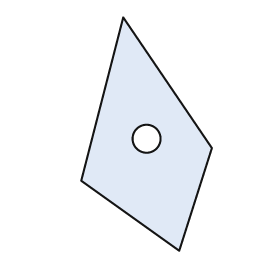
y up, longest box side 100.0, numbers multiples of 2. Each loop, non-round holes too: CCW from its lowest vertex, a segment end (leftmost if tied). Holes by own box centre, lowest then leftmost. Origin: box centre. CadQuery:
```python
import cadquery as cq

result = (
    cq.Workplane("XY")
    .moveTo(14.0, -50.0)
    .lineTo(28.0, -6.0)
    .lineTo(-10.0, 50.0)
    .lineTo(-28.0, -20.0)
    .close()
    .moveTo(0.0, -2.0)
    .circle(6.0)
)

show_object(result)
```